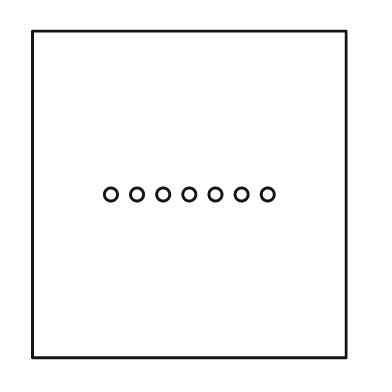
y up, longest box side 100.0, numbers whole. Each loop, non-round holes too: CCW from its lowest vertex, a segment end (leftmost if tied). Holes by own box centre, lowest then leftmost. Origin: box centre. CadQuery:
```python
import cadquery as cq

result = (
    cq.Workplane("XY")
    .moveTo(-48.0, -50.0)
    .lineTo(48.0, -50.0)
    .lineTo(48.0, 50.0)
    .lineTo(-48.0, 50.0)
    .close()
    .moveTo(-24.0, 0.0)
    .circle(2.0)
    .moveTo(-16.0, 0.0)
    .circle(2.0)
    .moveTo(-8.0, 0.0)
    .circle(2.0)
    .moveTo(0.0, 0.0)
    .circle(2.0)
    .moveTo(8.0, 0.0)
    .circle(2.0)
    .moveTo(16.0, 0.0)
    .circle(2.0)
    .moveTo(24.0, 0.0)
    .circle(2.0)
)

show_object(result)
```